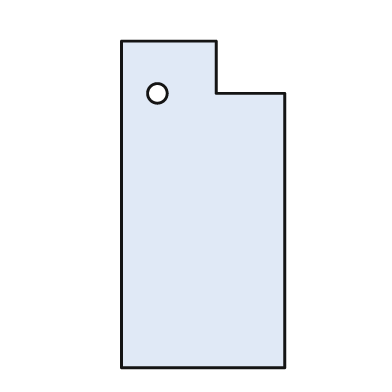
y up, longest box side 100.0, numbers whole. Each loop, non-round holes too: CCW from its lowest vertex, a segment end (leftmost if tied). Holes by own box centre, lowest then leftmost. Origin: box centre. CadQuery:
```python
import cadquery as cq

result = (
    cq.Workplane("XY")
    .moveTo(-25.0, -50.0)
    .lineTo(25.0, -50.0)
    .lineTo(25.0, 34.0)
    .lineTo(4.0, 34.0)
    .lineTo(4.0, 50.0)
    .lineTo(-25.0, 50.0)
    .close()
    .moveTo(-14.0, 34.0)
    .circle(3.0)
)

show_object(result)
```